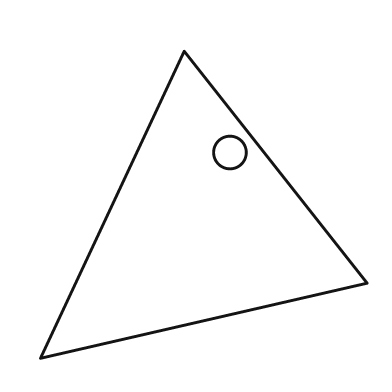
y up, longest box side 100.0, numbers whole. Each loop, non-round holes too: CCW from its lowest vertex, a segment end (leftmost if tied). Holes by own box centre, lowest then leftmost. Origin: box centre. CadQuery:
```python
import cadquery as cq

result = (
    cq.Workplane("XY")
    .moveTo(-50.0, -47.0)
    .lineTo(50.0, -24.0)
    .lineTo(-6.0, 47.0)
    .close()
    .moveTo(8.0, 16.0)
    .circle(5.0)
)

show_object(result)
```